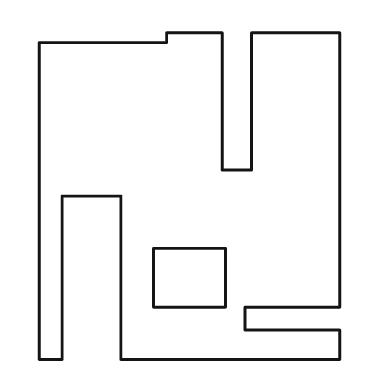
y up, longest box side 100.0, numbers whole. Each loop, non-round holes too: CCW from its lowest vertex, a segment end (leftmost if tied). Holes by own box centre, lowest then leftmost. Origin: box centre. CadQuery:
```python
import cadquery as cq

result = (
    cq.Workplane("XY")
    .moveTo(-46.0, -50.0)
    .lineTo(-39.0, -50.0)
    .lineTo(-39.0, 0.0)
    .lineTo(-21.0, 0.0)
    .lineTo(-21.0, -50.0)
    .lineTo(46.0, -50.0)
    .lineTo(46.0, -41.0)
    .lineTo(17.0, -41.0)
    .lineTo(17.0, -34.0)
    .lineTo(46.0, -34.0)
    .lineTo(46.0, 50.0)
    .lineTo(19.0, 50.0)
    .lineTo(19.0, 8.0)
    .lineTo(10.0, 8.0)
    .lineTo(10.0, 50.0)
    .lineTo(-7.0, 50.0)
    .lineTo(-7.0, 47.0)
    .lineTo(-46.0, 47.0)
    .close()
    .moveTo(-11.0, -34.0)
    .lineTo(11.0, -34.0)
    .lineTo(11.0, -16.0)
    .lineTo(-11.0, -16.0)
    .close()
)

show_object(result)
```